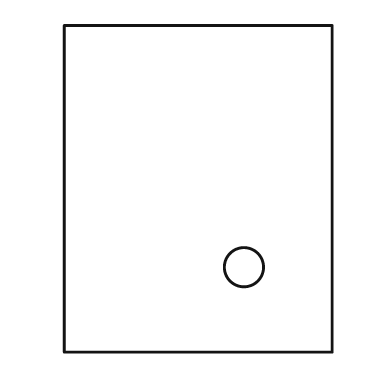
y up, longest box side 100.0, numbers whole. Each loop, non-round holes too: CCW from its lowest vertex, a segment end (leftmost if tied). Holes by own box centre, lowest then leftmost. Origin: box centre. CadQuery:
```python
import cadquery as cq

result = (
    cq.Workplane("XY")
    .moveTo(-41.0, -50.0)
    .lineTo(41.0, -50.0)
    .lineTo(41.0, 50.0)
    .lineTo(-41.0, 50.0)
    .close()
    .moveTo(14.0, -24.0)
    .circle(6.0)
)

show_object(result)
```